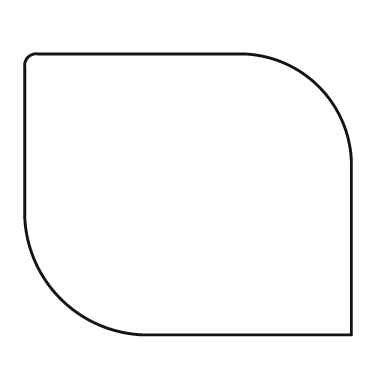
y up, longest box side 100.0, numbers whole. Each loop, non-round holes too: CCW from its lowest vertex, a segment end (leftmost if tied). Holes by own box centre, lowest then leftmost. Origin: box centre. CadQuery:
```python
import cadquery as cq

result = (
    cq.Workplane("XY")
    .moveTo(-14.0, -43.0)
    .lineTo(50.0, -43.0)
    .lineTo(50.0, 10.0)
    .threePointArc((40.0, 33.0), (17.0, 43.0))
    .lineTo(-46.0, 43.0)
    .threePointArc((-49.0, 42.0), (-50.0, 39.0))
    .lineTo(-50.0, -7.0)
    .threePointArc((-39.0, -32.0), (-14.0, -43.0))
    .close()
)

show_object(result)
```